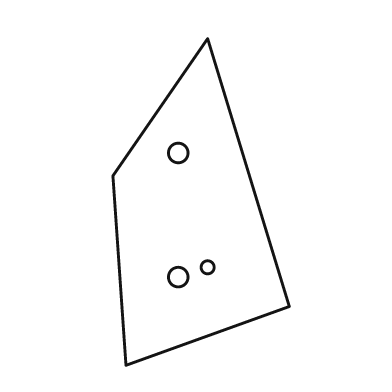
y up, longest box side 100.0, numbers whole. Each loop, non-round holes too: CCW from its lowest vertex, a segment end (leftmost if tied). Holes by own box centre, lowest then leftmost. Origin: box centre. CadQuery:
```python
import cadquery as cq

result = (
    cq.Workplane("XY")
    .moveTo(-23.0, -50.0)
    .lineTo(27.0, -32.0)
    .lineTo(2.0, 50.0)
    .lineTo(-27.0, 8.0)
    .close()
    .moveTo(-7.0, -23.0)
    .circle(3.0)
    .moveTo(2.0, -20.0)
    .circle(2.0)
    .moveTo(-7.0, 15.0)
    .circle(3.0)
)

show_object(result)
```